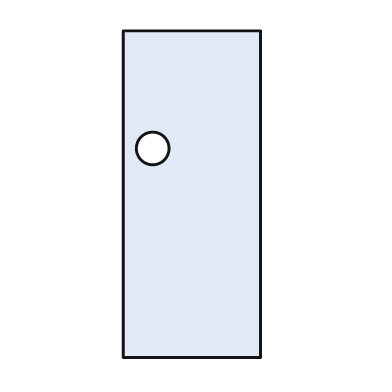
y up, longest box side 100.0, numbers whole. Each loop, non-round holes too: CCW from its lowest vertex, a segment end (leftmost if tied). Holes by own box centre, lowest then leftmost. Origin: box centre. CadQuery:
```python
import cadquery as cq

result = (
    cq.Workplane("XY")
    .moveTo(-21.0, -50.0)
    .lineTo(21.0, -50.0)
    .lineTo(21.0, 50.0)
    .lineTo(-21.0, 50.0)
    .close()
    .moveTo(-12.0, 14.0)
    .circle(5.0)
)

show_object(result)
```